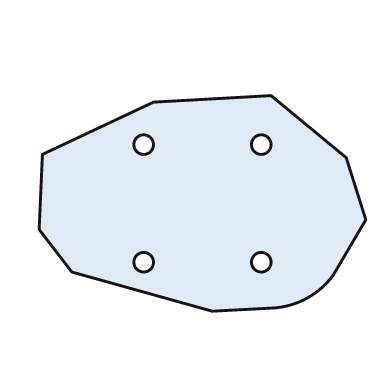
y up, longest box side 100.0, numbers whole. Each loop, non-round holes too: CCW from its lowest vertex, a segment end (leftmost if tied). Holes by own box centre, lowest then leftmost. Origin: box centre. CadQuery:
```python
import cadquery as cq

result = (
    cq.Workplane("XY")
    .moveTo(3.0, -33.0)
    .lineTo(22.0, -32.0)
    .threePointArc((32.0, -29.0), (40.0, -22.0))
    .lineTo(50.0, -5.0)
    .lineTo(44.0, 14.0)
    .lineTo(21.0, 33.0)
    .lineTo(-15.0, 31.0)
    .lineTo(-49.0, 15.0)
    .lineTo(-50.0, -8.0)
    .lineTo(-40.0, -21.0)
    .close()
    .moveTo(-18.0, -18.0)
    .circle(3.0)
    .moveTo(18.0, -18.0)
    .circle(3.0)
    .moveTo(-18.0, 18.0)
    .circle(3.0)
    .moveTo(18.0, 18.0)
    .circle(3.0)
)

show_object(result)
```